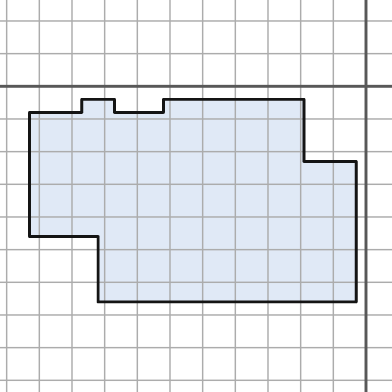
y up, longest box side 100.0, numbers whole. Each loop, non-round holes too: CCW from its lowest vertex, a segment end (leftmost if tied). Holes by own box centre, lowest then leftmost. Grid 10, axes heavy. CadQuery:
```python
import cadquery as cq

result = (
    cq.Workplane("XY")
    .moveTo(-82.0, -66.0)
    .lineTo(-3.0, -66.0)
    .lineTo(-3.0, -23.0)
    .lineTo(-19.0, -23.0)
    .lineTo(-19.0, -4.0)
    .lineTo(-62.0, -4.0)
    .lineTo(-62.0, -8.0)
    .lineTo(-77.0, -8.0)
    .lineTo(-77.0, -4.0)
    .lineTo(-87.0, -4.0)
    .lineTo(-87.0, -8.0)
    .lineTo(-103.0, -8.0)
    .lineTo(-103.0, -46.0)
    .lineTo(-82.0, -46.0)
    .close()
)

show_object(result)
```